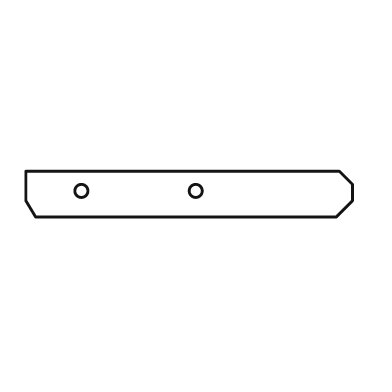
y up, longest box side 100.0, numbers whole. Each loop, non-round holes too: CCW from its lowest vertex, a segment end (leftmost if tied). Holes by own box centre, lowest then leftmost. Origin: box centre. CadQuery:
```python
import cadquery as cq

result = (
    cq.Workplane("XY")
    .moveTo(-47.0, -7.0)
    .lineTo(45.0, -7.0)
    .lineTo(50.0, -2.0)
    .lineTo(50.0, 3.0)
    .lineTo(46.0, 7.0)
    .lineTo(-50.0, 7.0)
    .lineTo(-50.0, -2.0)
    .close()
    .moveTo(-33.0, 1.0)
    .circle(2.0)
    .moveTo(2.0, 1.0)
    .circle(2.0)
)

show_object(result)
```